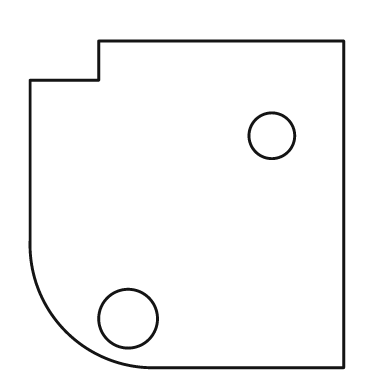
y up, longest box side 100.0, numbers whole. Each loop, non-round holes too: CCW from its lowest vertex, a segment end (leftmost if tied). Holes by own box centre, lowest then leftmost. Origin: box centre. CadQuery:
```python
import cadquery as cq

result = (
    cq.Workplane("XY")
    .moveTo(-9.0, -50.0)
    .lineTo(48.0, -50.0)
    .lineTo(48.0, 50.0)
    .lineTo(-27.0, 50.0)
    .lineTo(-27.0, 38.0)
    .lineTo(-48.0, 38.0)
    .lineTo(-48.0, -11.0)
    .threePointArc((-37.0, -39.0), (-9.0, -50.0))
    .close()
    .moveTo(-18.0, -35.0)
    .circle(9.0)
    .moveTo(26.0, 21.0)
    .circle(7.0)
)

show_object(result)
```